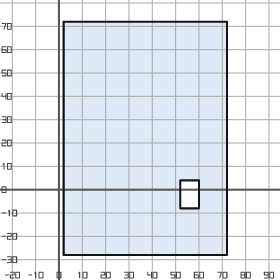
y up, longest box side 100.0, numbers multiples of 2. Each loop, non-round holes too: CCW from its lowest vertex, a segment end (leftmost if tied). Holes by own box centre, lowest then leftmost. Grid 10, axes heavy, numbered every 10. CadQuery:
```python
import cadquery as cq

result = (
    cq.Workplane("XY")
    .moveTo(2.0, -28.0)
    .lineTo(72.0, -28.0)
    .lineTo(72.0, 72.0)
    .lineTo(2.0, 72.0)
    .close()
    .moveTo(52.0, -8.0)
    .lineTo(60.0, -8.0)
    .lineTo(60.0, 4.0)
    .lineTo(52.0, 4.0)
    .close()
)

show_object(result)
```